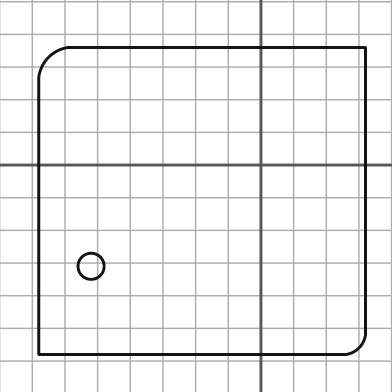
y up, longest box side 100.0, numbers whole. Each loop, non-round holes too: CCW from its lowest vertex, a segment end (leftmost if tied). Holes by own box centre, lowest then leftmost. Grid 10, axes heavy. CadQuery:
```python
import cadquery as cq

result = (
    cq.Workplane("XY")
    .moveTo(-68.0, -58.0)
    .lineTo(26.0, -58.0)
    .threePointArc((30.0, -56.0), (32.0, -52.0))
    .lineTo(32.0, 36.0)
    .lineTo(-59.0, 36.0)
    .threePointArc((-65.0, 33.0), (-68.0, 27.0))
    .close()
    .moveTo(-52.0, -31.0)
    .circle(4.0)
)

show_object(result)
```